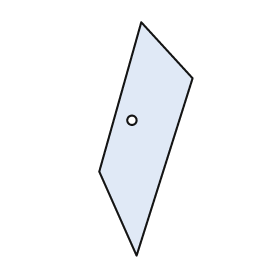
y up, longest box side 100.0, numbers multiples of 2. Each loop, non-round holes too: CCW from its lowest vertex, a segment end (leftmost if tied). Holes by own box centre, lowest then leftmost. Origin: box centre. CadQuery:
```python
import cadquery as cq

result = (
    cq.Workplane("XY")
    .moveTo(-4.0, -50.0)
    .lineTo(20.0, 26.0)
    .lineTo(-2.0, 50.0)
    .lineTo(-20.0, -14.0)
    .close()
    .moveTo(-6.0, 8.0)
    .circle(2.0)
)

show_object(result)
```